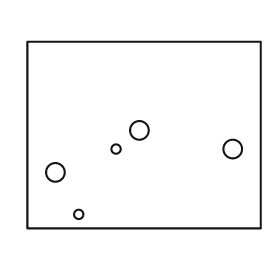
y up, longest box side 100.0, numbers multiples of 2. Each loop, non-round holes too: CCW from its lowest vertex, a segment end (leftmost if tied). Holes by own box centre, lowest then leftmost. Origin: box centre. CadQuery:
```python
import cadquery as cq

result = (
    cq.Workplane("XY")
    .moveTo(-50.0, -40.0)
    .lineTo(50.0, -40.0)
    .lineTo(50.0, 40.0)
    .lineTo(-50.0, 40.0)
    .close()
    .moveTo(-28.0, -34.0)
    .circle(2.0)
    .moveTo(-38.0, -16.0)
    .circle(4.0)
    .moveTo(-12.0, -6.0)
    .circle(2.0)
    .moveTo(38.0, -6.0)
    .circle(4.0)
    .moveTo(-2.0, 2.0)
    .circle(4.0)
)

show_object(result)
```